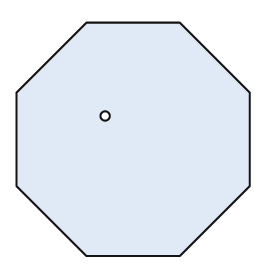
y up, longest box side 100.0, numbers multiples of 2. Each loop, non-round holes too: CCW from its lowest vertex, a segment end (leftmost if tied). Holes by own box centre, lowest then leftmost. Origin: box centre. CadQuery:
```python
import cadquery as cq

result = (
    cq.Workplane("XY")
    .moveTo(-20.0, -50.0)
    .lineTo(20.0, -50.0)
    .lineTo(50.0, -20.0)
    .lineTo(50.0, 20.0)
    .lineTo(20.0, 50.0)
    .lineTo(-20.0, 50.0)
    .lineTo(-50.0, 20.0)
    .lineTo(-50.0, -20.0)
    .close()
    .moveTo(-12.0, 10.0)
    .circle(2.0)
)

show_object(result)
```